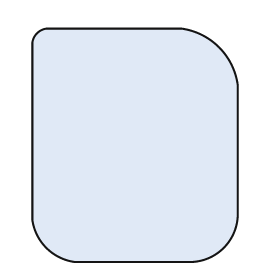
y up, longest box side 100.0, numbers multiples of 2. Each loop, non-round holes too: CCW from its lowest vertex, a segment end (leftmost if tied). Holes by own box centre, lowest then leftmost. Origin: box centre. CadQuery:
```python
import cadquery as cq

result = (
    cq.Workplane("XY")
    .moveTo(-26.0, -50.0)
    .lineTo(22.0, -50.0)
    .threePointArc((38.0, -44.0), (44.0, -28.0))
    .lineTo(44.0, 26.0)
    .threePointArc((36.0, 42.0), (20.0, 50.0))
    .lineTo(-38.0, 50.0)
    .threePointArc((-42.0, 48.0), (-44.0, 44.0))
    .lineTo(-44.0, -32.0)
    .threePointArc((-38.0, -44.0), (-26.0, -50.0))
    .close()
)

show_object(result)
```